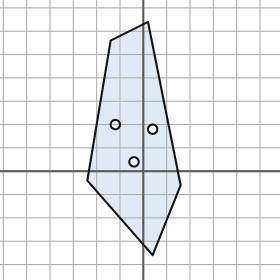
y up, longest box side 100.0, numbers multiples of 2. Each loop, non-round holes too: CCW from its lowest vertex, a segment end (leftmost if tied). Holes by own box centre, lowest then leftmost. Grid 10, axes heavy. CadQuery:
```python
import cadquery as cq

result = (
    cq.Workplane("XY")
    .moveTo(4.0, -36.0)
    .lineTo(16.0, -6.0)
    .lineTo(2.0, 64.0)
    .lineTo(-14.0, 56.0)
    .lineTo(-24.0, -4.0)
    .close()
    .moveTo(-4.0, 4.0)
    .circle(2.0)
    .moveTo(4.0, 18.0)
    .circle(2.0)
    .moveTo(-12.0, 20.0)
    .circle(2.0)
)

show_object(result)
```